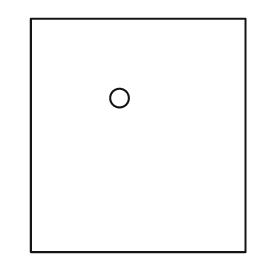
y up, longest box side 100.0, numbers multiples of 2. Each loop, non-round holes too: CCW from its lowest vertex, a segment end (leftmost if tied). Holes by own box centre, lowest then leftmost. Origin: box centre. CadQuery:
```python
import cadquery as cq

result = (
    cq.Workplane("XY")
    .moveTo(-46.0, -50.0)
    .lineTo(46.0, -50.0)
    .lineTo(46.0, 50.0)
    .lineTo(-46.0, 50.0)
    .close()
    .moveTo(-8.0, 16.0)
    .circle(4.0)
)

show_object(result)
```